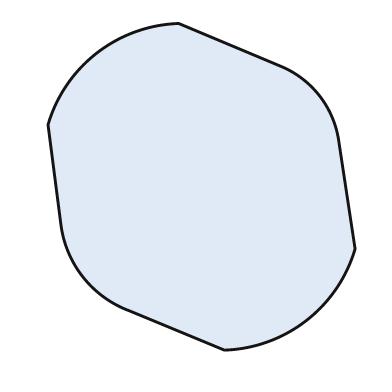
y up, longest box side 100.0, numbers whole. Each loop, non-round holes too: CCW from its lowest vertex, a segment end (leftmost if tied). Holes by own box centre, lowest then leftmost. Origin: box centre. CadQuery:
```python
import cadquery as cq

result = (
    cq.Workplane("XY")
    .moveTo(7.0, -50.0)
    .threePointArc((32.0, -41.0), (47.0, -19.0))
    .lineTo(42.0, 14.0)
    .threePointArc((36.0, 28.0), (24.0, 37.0))
    .lineTo(-7.0, 50.0)
    .threePointArc((-32.0, 41.0), (-47.0, 19.0))
    .lineTo(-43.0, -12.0)
    .threePointArc((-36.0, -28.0), (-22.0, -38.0))
    .close()
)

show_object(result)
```